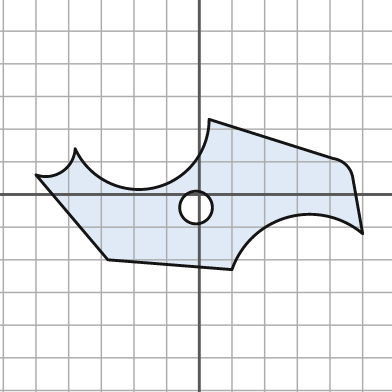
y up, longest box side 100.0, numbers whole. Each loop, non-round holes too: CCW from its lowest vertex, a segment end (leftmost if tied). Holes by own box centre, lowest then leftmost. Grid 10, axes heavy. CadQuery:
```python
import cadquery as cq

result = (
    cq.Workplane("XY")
    .moveTo(10.0, -23.0)
    .threePointArc((27.0, -7.0), (50.0, -12.0))
    .lineTo(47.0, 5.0)
    .threePointArc((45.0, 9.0), (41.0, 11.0))
    .lineTo(3.0, 23.0)
    .threePointArc((-14.0, 2.0), (-38.0, 14.0))
    .threePointArc((-42.0, 7.0), (-50.0, 6.0))
    .lineTo(-28.0, -20.0)
    .close()
    .moveTo(-1.0, -4.0)
    .circle(5.0)
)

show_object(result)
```